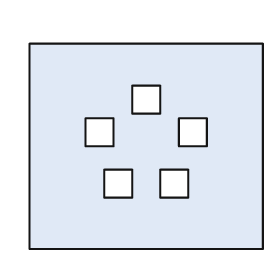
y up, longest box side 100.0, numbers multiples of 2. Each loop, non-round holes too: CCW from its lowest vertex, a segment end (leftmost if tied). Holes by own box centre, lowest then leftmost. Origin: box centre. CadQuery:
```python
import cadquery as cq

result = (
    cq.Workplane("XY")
    .moveTo(-50.0, -44.0)
    .lineTo(50.0, -44.0)
    .lineTo(50.0, 44.0)
    .lineTo(-50.0, 44.0)
    .close()
    .moveTo(-18.0, -22.0)
    .lineTo(-6.0, -22.0)
    .lineTo(-6.0, -10.0)
    .lineTo(-18.0, -10.0)
    .close()
    .moveTo(6.0, -22.0)
    .lineTo(18.0, -22.0)
    .lineTo(18.0, -10.0)
    .lineTo(6.0, -10.0)
    .close()
    .moveTo(-26.0, 0.0)
    .lineTo(-14.0, 0.0)
    .lineTo(-14.0, 12.0)
    .lineTo(-26.0, 12.0)
    .close()
    .moveTo(14.0, 0.0)
    .lineTo(26.0, 0.0)
    .lineTo(26.0, 12.0)
    .lineTo(14.0, 12.0)
    .close()
    .moveTo(-6.0, 14.0)
    .lineTo(6.0, 14.0)
    .lineTo(6.0, 26.0)
    .lineTo(-6.0, 26.0)
    .close()
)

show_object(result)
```